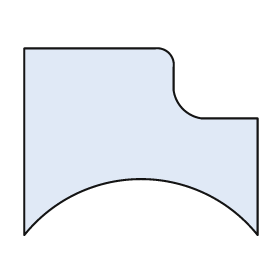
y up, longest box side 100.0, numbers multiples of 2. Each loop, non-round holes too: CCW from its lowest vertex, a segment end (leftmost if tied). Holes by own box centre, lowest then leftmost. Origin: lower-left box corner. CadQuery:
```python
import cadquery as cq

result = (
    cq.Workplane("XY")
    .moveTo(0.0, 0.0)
    .threePointArc((50.0, 24.0), (100.0, 0.0))
    .lineTo(100.0, 50.0)
    .lineTo(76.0, 50.0)
    .threePointArc((68.0, 54.0), (64.0, 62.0))
    .lineTo(64.0, 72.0)
    .threePointArc((62.0, 78.0), (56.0, 80.0))
    .lineTo(0.0, 80.0)
    .close()
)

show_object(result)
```